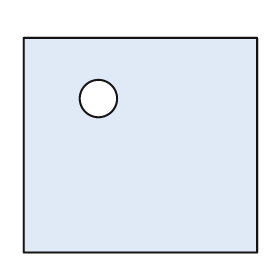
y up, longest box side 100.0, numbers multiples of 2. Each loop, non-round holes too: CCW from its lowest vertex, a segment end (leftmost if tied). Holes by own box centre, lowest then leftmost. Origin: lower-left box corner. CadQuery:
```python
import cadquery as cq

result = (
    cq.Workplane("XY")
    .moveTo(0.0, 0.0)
    .lineTo(100.0, 0.0)
    .lineTo(100.0, 92.0)
    .lineTo(0.0, 92.0)
    .close()
    .moveTo(32.0, 66.0)
    .circle(8.0)
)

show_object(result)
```